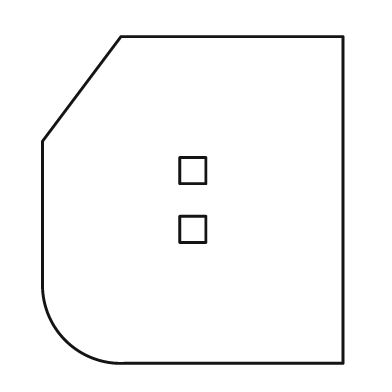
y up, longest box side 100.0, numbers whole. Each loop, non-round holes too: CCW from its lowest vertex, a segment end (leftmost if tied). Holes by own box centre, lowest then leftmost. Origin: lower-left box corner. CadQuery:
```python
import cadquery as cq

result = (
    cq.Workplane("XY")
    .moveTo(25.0, 0.0)
    .lineTo(92.0, 0.0)
    .lineTo(92.0, 100.0)
    .lineTo(24.0, 100.0)
    .lineTo(0.0, 68.0)
    .lineTo(0.0, 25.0)
    .threePointArc((7.0, 7.0), (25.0, 0.0))
    .close()
    .moveTo(42.0, 37.0)
    .lineTo(50.0, 37.0)
    .lineTo(50.0, 45.0)
    .lineTo(42.0, 45.0)
    .close()
    .moveTo(42.0, 55.0)
    .lineTo(50.0, 55.0)
    .lineTo(50.0, 63.0)
    .lineTo(42.0, 63.0)
    .close()
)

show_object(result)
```